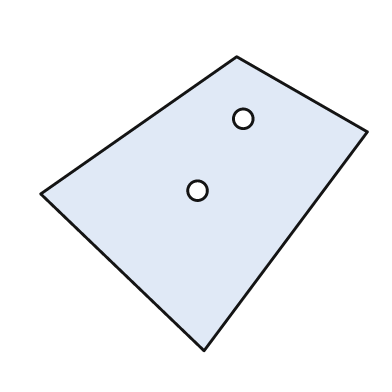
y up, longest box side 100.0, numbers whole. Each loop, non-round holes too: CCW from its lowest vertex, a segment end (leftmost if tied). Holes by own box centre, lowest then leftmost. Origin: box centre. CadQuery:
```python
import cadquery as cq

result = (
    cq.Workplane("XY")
    .moveTo(0.0, -45.0)
    .lineTo(50.0, 22.0)
    .lineTo(10.0, 45.0)
    .lineTo(-50.0, 3.0)
    .close()
    .moveTo(-2.0, 4.0)
    .circle(3.0)
    .moveTo(12.0, 26.0)
    .circle(3.0)
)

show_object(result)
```